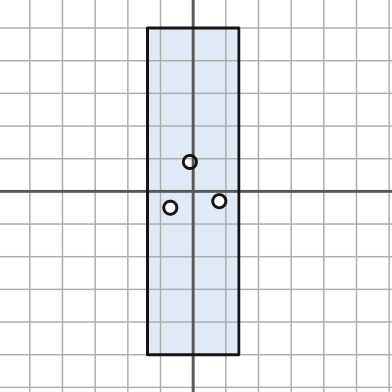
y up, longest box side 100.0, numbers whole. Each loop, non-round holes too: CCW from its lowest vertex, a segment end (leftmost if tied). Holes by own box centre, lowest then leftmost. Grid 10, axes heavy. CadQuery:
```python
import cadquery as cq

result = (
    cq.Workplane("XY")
    .moveTo(-14.0, -50.0)
    .lineTo(14.0, -50.0)
    .lineTo(14.0, 50.0)
    .lineTo(-14.0, 50.0)
    .close()
    .moveTo(-7.0, -5.0)
    .circle(2.0)
    .moveTo(8.0, -3.0)
    .circle(2.0)
    .moveTo(-1.0, 9.0)
    .circle(2.0)
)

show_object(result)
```